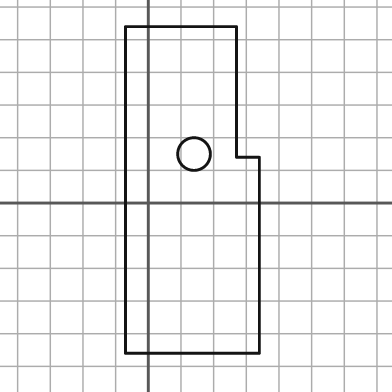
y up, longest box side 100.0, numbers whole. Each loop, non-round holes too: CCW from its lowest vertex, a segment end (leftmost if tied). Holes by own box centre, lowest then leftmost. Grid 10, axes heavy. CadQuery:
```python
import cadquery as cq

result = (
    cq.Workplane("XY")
    .moveTo(-7.0, -46.0)
    .lineTo(34.0, -46.0)
    .lineTo(34.0, 14.0)
    .lineTo(27.0, 14.0)
    .lineTo(27.0, 54.0)
    .lineTo(-7.0, 54.0)
    .close()
    .moveTo(14.0, 15.0)
    .circle(5.0)
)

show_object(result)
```